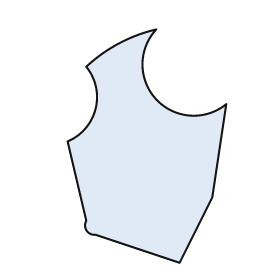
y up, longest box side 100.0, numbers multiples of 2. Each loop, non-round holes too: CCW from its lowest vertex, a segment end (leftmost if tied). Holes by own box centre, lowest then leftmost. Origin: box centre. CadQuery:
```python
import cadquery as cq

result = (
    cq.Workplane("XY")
    .moveTo(14.0, -50.0)
    .lineTo(28.0, -22.0)
    .lineTo(34.0, 18.0)
    .threePointArc((4.0, 20.0), (4.0, 50.0))
    .threePointArc((-12.0, 44.0), (-26.0, 34.0))
    .threePointArc((-22.0, 16.0), (-34.0, 2.0))
    .lineTo(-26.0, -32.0)
    .threePointArc((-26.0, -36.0), (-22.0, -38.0))
    .close()
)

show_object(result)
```